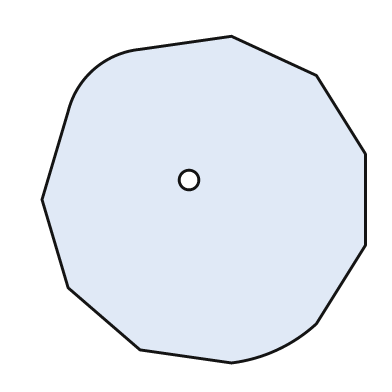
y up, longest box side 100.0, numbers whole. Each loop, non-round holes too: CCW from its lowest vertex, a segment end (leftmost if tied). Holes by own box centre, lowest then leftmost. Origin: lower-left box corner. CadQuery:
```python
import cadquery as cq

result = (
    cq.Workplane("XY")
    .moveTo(58.0, 0.0)
    .threePointArc((72.0, 4.0), (84.0, 12.0))
    .lineTo(99.0, 36.0)
    .lineTo(99.0, 64.0)
    .lineTo(84.0, 88.0)
    .lineTo(58.0, 100.0)
    .lineTo(30.0, 96.0)
    .threePointArc((16.0, 90.0), (8.0, 77.0))
    .lineTo(0.0, 50.0)
    .lineTo(8.0, 23.0)
    .lineTo(30.0, 4.0)
    .close()
    .moveTo(45.0, 56.0)
    .circle(3.0)
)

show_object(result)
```